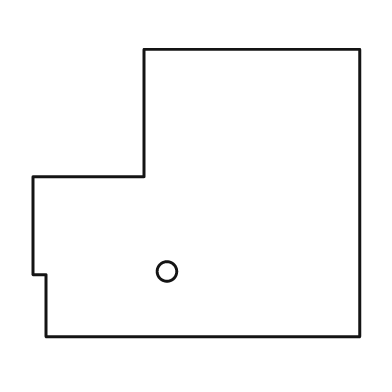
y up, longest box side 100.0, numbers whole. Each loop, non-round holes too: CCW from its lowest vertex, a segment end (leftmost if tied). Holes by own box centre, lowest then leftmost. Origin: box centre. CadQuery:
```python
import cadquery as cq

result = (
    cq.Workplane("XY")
    .moveTo(-46.0, -44.0)
    .lineTo(50.0, -44.0)
    .lineTo(50.0, 44.0)
    .lineTo(-16.0, 44.0)
    .lineTo(-16.0, 5.0)
    .lineTo(-50.0, 5.0)
    .lineTo(-50.0, -25.0)
    .lineTo(-46.0, -25.0)
    .close()
    .moveTo(-9.0, -24.0)
    .circle(3.0)
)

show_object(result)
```